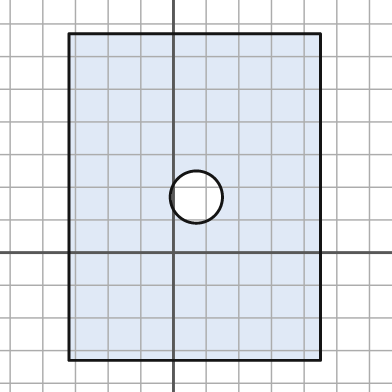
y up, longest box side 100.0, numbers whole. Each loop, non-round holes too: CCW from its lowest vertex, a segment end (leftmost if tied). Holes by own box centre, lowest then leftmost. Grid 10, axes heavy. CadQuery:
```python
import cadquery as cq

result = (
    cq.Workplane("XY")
    .moveTo(-32.0, -33.0)
    .lineTo(45.0, -33.0)
    .lineTo(45.0, 67.0)
    .lineTo(-32.0, 67.0)
    .close()
    .moveTo(7.0, 17.0)
    .circle(8.0)
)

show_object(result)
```